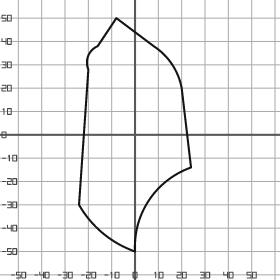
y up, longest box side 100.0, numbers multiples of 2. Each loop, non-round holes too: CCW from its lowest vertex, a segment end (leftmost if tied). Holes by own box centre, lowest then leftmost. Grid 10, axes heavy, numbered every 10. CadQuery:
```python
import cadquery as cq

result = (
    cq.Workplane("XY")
    .moveTo(0.0, -50.0)
    .threePointArc((6.0, -28.0), (24.0, -14.0))
    .lineTo(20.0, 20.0)
    .threePointArc((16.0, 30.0), (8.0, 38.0))
    .lineTo(-8.0, 50.0)
    .lineTo(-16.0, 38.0)
    .threePointArc((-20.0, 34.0), (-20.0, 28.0))
    .lineTo(-24.0, -30.0)
    .threePointArc((-14.0, -42.0), (0.0, -50.0))
    .close()
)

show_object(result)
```